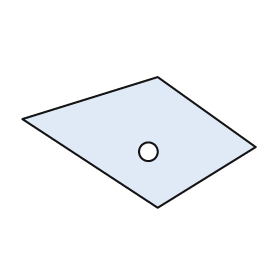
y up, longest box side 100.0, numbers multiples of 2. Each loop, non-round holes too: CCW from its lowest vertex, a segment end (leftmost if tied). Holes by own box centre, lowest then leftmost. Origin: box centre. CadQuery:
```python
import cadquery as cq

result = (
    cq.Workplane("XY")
    .moveTo(8.0, -28.0)
    .lineTo(50.0, -2.0)
    .lineTo(8.0, 28.0)
    .lineTo(-50.0, 10.0)
    .close()
    .moveTo(4.0, -4.0)
    .circle(4.0)
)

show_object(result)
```